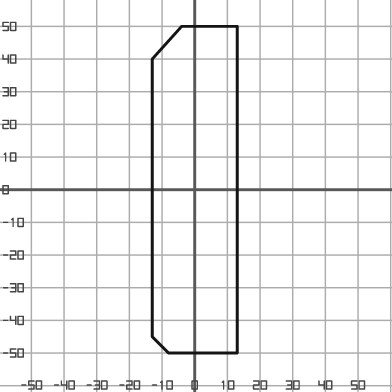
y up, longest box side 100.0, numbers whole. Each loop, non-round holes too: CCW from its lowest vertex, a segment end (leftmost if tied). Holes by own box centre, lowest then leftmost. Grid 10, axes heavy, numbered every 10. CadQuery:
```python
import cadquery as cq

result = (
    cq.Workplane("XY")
    .moveTo(-8.0, -50.0)
    .lineTo(13.0, -50.0)
    .lineTo(13.0, 50.0)
    .lineTo(-4.0, 50.0)
    .lineTo(-13.0, 40.0)
    .lineTo(-13.0, -45.0)
    .close()
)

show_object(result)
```